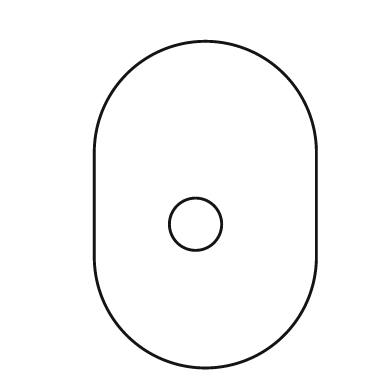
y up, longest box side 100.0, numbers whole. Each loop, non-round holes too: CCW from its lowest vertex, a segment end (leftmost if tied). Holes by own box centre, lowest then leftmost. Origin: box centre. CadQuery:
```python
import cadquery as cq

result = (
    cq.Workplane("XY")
    .moveTo(-34.0, -16.0)
    .threePointArc((0.0, -50.0), (34.0, -16.0))
    .lineTo(34.0, 16.0)
    .threePointArc((0.0, 50.0), (-34.0, 16.0))
    .close()
    .moveTo(-3.0, -6.0)
    .circle(8.0)
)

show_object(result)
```